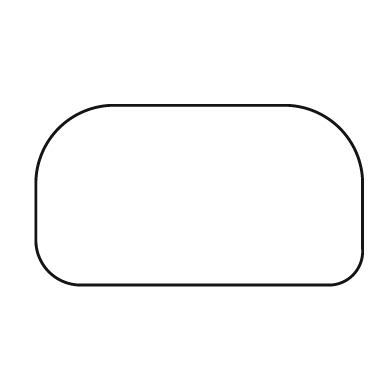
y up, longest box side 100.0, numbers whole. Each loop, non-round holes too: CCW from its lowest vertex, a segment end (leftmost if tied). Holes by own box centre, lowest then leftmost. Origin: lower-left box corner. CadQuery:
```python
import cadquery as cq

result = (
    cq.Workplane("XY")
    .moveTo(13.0, 0.0)
    .lineTo(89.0, 0.0)
    .threePointArc((97.0, 3.0), (100.0, 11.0))
    .lineTo(100.0, 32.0)
    .threePointArc((93.0, 48.0), (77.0, 55.0))
    .lineTo(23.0, 55.0)
    .threePointArc((7.0, 48.0), (0.0, 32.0))
    .lineTo(0.0, 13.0)
    .threePointArc((4.0, 4.0), (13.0, 0.0))
    .close()
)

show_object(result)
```